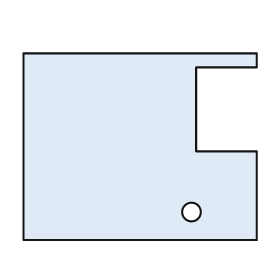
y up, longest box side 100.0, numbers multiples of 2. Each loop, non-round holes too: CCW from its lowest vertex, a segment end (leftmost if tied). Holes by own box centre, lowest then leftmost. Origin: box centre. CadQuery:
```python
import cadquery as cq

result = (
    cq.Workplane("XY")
    .moveTo(-50.0, -40.0)
    .lineTo(50.0, -40.0)
    .lineTo(50.0, -2.0)
    .lineTo(24.0, -2.0)
    .lineTo(24.0, 34.0)
    .lineTo(50.0, 34.0)
    .lineTo(50.0, 40.0)
    .lineTo(-50.0, 40.0)
    .close()
    .moveTo(22.0, -28.0)
    .circle(4.0)
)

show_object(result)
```